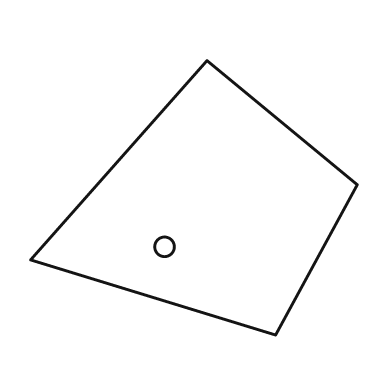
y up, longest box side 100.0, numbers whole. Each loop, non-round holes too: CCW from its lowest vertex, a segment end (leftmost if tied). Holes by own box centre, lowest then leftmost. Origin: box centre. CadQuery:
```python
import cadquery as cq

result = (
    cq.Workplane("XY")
    .moveTo(25.0, -42.0)
    .lineTo(50.0, 4.0)
    .lineTo(4.0, 42.0)
    .lineTo(-50.0, -19.0)
    .close()
    .moveTo(-9.0, -15.0)
    .circle(3.0)
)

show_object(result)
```